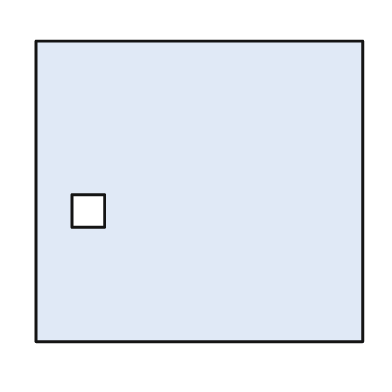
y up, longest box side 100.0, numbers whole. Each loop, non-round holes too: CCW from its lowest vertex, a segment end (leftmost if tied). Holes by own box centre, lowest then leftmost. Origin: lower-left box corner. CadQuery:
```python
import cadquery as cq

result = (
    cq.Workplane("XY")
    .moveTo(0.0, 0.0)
    .lineTo(100.0, 0.0)
    .lineTo(100.0, 92.0)
    .lineTo(0.0, 92.0)
    .close()
    .moveTo(11.0, 35.0)
    .lineTo(21.0, 35.0)
    .lineTo(21.0, 45.0)
    .lineTo(11.0, 45.0)
    .close()
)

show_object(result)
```